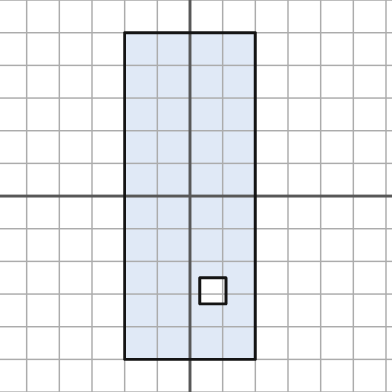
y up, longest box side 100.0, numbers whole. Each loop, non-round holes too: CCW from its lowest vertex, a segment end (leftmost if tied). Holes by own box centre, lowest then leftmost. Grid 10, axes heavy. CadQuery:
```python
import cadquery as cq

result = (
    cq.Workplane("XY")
    .moveTo(-20.0, -50.0)
    .lineTo(20.0, -50.0)
    .lineTo(20.0, 50.0)
    .lineTo(-20.0, 50.0)
    .close()
    .moveTo(3.0, -33.0)
    .lineTo(11.0, -33.0)
    .lineTo(11.0, -25.0)
    .lineTo(3.0, -25.0)
    .close()
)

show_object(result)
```